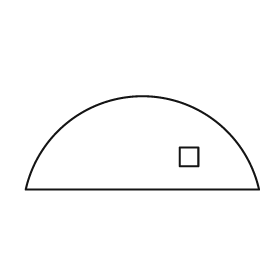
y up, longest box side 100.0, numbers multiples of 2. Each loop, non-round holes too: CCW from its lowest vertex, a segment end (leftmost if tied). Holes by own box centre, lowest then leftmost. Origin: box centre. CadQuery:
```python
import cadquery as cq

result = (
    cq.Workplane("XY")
    .moveTo(-50.0, -20.0)
    .lineTo(50.0, -20.0)
    .threePointArc((0.0, 20.0), (-50.0, -20.0))
    .close()
    .moveTo(16.0, -10.0)
    .lineTo(24.0, -10.0)
    .lineTo(24.0, -2.0)
    .lineTo(16.0, -2.0)
    .close()
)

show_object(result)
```